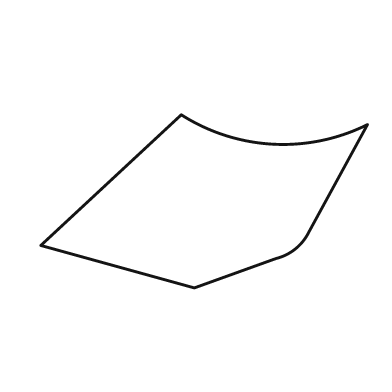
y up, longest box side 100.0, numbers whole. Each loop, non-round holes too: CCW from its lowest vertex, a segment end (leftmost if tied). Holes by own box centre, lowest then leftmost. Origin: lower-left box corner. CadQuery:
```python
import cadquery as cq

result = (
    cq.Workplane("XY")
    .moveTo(47.0, 0.0)
    .lineTo(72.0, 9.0)
    .threePointArc((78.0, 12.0), (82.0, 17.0))
    .lineTo(100.0, 50.0)
    .threePointArc((71.0, 44.0), (43.0, 53.0))
    .lineTo(0.0, 13.0)
    .close()
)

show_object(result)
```